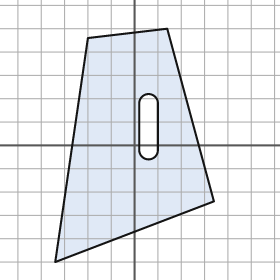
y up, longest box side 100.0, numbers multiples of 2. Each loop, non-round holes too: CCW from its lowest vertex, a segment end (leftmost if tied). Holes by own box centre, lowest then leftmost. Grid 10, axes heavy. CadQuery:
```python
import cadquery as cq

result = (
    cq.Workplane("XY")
    .moveTo(-34.0, -50.0)
    .lineTo(34.0, -24.0)
    .lineTo(14.0, 50.0)
    .lineTo(-20.0, 46.0)
    .close()
    .moveTo(2.0, -2.0)
    .threePointArc((6.0, -6.0), (10.0, -2.0))
    .lineTo(10.0, 18.0)
    .threePointArc((6.0, 22.0), (2.0, 18.0))
    .close()
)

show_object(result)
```